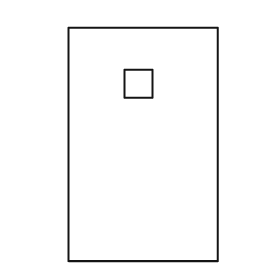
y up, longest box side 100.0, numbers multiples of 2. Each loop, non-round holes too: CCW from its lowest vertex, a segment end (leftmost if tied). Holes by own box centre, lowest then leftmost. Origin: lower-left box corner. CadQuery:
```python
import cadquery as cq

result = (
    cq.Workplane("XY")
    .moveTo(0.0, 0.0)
    .lineTo(64.0, 0.0)
    .lineTo(64.0, 100.0)
    .lineTo(0.0, 100.0)
    .close()
    .moveTo(24.0, 70.0)
    .lineTo(36.0, 70.0)
    .lineTo(36.0, 82.0)
    .lineTo(24.0, 82.0)
    .close()
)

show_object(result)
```